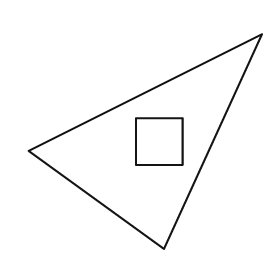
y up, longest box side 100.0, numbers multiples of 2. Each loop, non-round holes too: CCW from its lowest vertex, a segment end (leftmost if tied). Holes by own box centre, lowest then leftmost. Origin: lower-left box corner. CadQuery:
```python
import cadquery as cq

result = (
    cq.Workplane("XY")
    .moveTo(58.0, 0.0)
    .lineTo(100.0, 92.0)
    .lineTo(0.0, 42.0)
    .close()
    .moveTo(46.0, 36.0)
    .lineTo(66.0, 36.0)
    .lineTo(66.0, 56.0)
    .lineTo(46.0, 56.0)
    .close()
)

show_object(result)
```